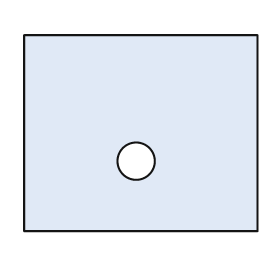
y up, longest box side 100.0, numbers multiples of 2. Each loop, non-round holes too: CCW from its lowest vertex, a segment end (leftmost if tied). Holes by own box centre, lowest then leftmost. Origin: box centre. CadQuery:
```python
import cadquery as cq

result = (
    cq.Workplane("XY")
    .moveTo(-50.0, -42.0)
    .lineTo(50.0, -42.0)
    .lineTo(50.0, 42.0)
    .lineTo(-50.0, 42.0)
    .close()
    .moveTo(-2.0, -12.0)
    .circle(8.0)
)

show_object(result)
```